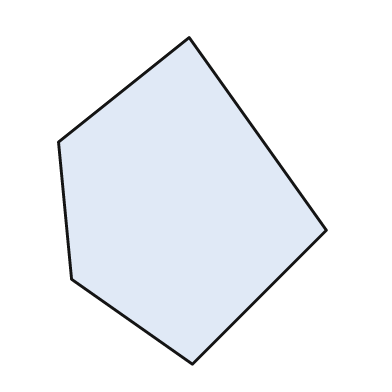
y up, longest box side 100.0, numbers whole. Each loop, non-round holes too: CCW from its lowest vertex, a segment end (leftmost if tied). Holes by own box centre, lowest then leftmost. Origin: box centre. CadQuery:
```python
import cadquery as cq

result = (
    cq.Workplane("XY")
    .moveTo(0.0, -50.0)
    .lineTo(41.0, -9.0)
    .lineTo(-1.0, 50.0)
    .lineTo(-41.0, 18.0)
    .lineTo(-37.0, -24.0)
    .close()
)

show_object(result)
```